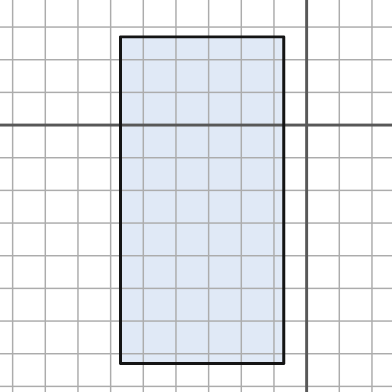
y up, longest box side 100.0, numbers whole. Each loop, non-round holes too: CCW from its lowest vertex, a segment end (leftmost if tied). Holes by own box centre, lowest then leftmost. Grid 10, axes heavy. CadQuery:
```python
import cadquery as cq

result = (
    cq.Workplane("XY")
    .moveTo(-57.0, -73.0)
    .lineTo(-7.0, -73.0)
    .lineTo(-7.0, 27.0)
    .lineTo(-57.0, 27.0)
    .close()
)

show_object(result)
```